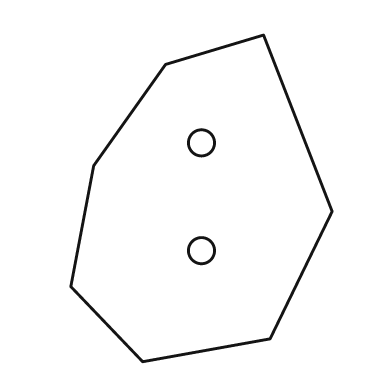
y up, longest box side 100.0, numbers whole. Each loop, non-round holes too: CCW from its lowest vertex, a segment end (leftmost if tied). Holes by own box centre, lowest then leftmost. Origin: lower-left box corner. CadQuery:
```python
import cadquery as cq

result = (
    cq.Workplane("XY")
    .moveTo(22.0, 0.0)
    .lineTo(61.0, 7.0)
    .lineTo(80.0, 46.0)
    .lineTo(59.0, 100.0)
    .lineTo(29.0, 91.0)
    .lineTo(7.0, 60.0)
    .lineTo(0.0, 23.0)
    .close()
    .moveTo(40.0, 34.0)
    .circle(4.0)
    .moveTo(40.0, 67.0)
    .circle(4.0)
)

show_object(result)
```